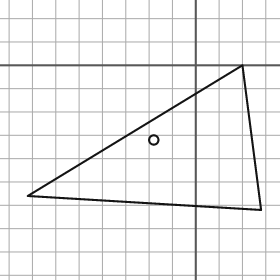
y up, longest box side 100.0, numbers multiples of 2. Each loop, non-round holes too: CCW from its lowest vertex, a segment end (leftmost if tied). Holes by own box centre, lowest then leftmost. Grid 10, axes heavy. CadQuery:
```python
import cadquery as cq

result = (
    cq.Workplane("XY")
    .moveTo(28.0, -62.0)
    .lineTo(20.0, 0.0)
    .lineTo(-72.0, -56.0)
    .close()
    .moveTo(-18.0, -32.0)
    .circle(2.0)
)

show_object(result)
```